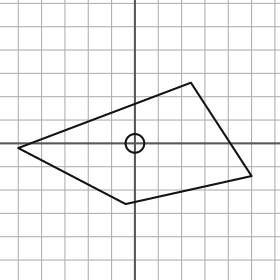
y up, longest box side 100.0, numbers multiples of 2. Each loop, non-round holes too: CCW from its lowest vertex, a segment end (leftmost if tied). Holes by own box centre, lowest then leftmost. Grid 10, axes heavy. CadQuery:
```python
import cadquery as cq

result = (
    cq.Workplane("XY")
    .moveTo(-4.0, -26.0)
    .lineTo(50.0, -14.0)
    .lineTo(24.0, 26.0)
    .lineTo(-50.0, -2.0)
    .close()
    .moveTo(0.0, 0.0)
    .circle(4.0)
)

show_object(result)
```